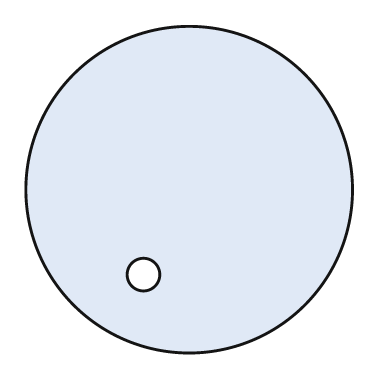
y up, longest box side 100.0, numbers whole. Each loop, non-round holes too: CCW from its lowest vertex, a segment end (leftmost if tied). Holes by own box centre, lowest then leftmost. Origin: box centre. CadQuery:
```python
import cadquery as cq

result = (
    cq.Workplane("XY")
    .moveTo(0.0, 0.0)
    .circle(50.0)
    .moveTo(-14.0, -26.0)
    .circle(5.0)
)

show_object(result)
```